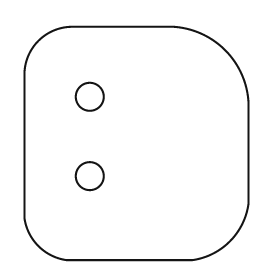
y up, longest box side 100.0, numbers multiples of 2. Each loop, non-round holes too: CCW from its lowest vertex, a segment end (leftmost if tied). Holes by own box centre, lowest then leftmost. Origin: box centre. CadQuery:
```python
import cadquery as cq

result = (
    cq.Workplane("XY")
    .moveTo(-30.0, -50.0)
    .lineTo(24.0, -50.0)
    .threePointArc((40.0, -42.0), (48.0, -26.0))
    .lineTo(48.0, 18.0)
    .threePointArc((38.0, 40.0), (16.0, 50.0))
    .lineTo(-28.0, 50.0)
    .threePointArc((-42.0, 44.0), (-48.0, 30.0))
    .lineTo(-48.0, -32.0)
    .threePointArc((-42.0, -44.0), (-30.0, -50.0))
    .close()
    .moveTo(-20.0, -14.0)
    .circle(6.0)
    .moveTo(-20.0, 20.0)
    .circle(6.0)
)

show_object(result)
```